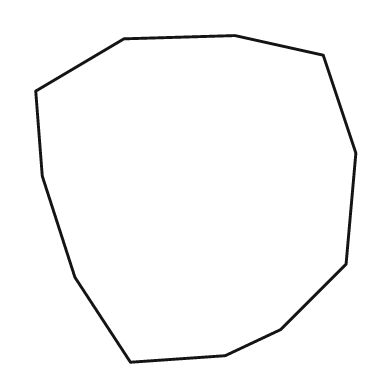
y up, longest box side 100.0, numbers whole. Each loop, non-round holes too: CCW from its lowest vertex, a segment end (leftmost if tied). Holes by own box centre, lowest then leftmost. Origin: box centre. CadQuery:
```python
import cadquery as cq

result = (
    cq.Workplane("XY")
    .moveTo(-20.0, -50.0)
    .lineTo(9.0, -48.0)
    .lineTo(26.0, -40.0)
    .lineTo(46.0, -20.0)
    .lineTo(49.0, 14.0)
    .lineTo(39.0, 44.0)
    .lineTo(12.0, 50.0)
    .lineTo(-22.0, 49.0)
    .lineTo(-49.0, 33.0)
    .lineTo(-47.0, 7.0)
    .lineTo(-37.0, -24.0)
    .close()
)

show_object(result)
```